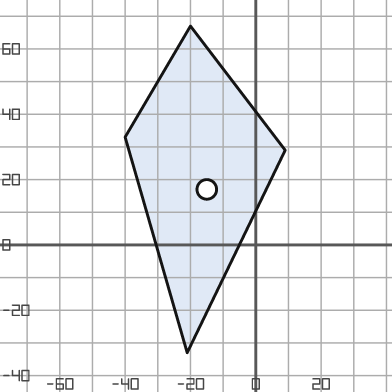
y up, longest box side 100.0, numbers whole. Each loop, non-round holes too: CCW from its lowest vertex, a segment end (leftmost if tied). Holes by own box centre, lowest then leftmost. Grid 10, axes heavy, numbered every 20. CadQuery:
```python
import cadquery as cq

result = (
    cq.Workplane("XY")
    .moveTo(-21.0, -33.0)
    .lineTo(9.0, 29.0)
    .lineTo(-20.0, 67.0)
    .lineTo(-40.0, 33.0)
    .close()
    .moveTo(-15.0, 17.0)
    .circle(3.0)
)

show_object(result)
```